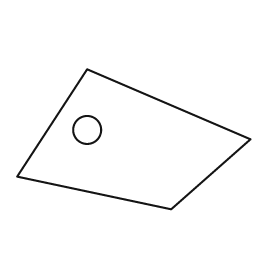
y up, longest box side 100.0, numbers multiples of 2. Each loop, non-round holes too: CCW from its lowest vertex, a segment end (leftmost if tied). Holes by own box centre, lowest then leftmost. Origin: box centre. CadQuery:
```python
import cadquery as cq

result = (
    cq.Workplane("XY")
    .moveTo(16.0, -30.0)
    .lineTo(50.0, 0.0)
    .lineTo(-20.0, 30.0)
    .lineTo(-50.0, -16.0)
    .close()
    .moveTo(-20.0, 4.0)
    .circle(6.0)
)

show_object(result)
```